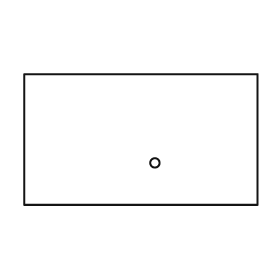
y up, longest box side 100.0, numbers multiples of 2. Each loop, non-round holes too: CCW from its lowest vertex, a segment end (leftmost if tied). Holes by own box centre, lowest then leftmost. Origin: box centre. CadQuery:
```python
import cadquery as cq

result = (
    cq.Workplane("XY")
    .moveTo(-50.0, -28.0)
    .lineTo(50.0, -28.0)
    .lineTo(50.0, 28.0)
    .lineTo(-50.0, 28.0)
    .close()
    .moveTo(6.0, -10.0)
    .circle(2.0)
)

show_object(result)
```